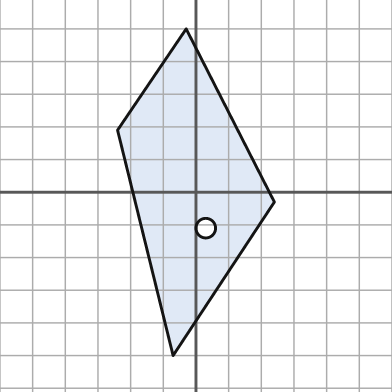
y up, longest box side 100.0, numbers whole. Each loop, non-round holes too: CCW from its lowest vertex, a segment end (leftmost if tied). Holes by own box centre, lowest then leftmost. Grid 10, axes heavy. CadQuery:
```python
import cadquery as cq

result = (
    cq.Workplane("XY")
    .moveTo(-7.0, -50.0)
    .lineTo(24.0, -3.0)
    .lineTo(-3.0, 50.0)
    .lineTo(-24.0, 19.0)
    .close()
    .moveTo(3.0, -11.0)
    .circle(3.0)
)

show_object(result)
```